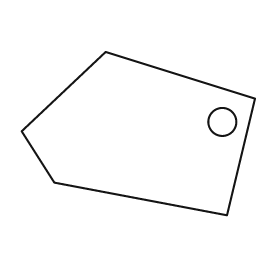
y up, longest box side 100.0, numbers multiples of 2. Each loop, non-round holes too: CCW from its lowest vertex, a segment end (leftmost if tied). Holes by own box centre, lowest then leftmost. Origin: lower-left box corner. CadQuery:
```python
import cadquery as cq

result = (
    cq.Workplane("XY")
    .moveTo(88.0, 0.0)
    .lineTo(100.0, 50.0)
    .lineTo(36.0, 70.0)
    .lineTo(0.0, 36.0)
    .lineTo(14.0, 14.0)
    .close()
    .moveTo(86.0, 40.0)
    .circle(6.0)
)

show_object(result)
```